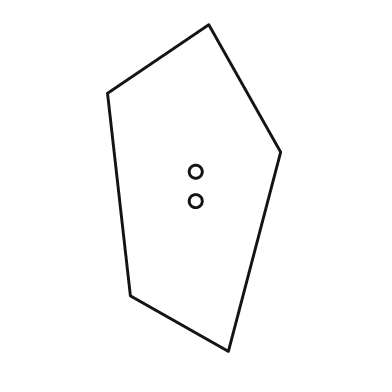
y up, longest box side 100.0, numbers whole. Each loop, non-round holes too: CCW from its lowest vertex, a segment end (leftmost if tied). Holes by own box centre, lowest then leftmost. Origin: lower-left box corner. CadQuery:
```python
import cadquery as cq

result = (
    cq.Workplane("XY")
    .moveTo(37.0, 0.0)
    .lineTo(53.0, 61.0)
    .lineTo(31.0, 100.0)
    .lineTo(0.0, 79.0)
    .lineTo(7.0, 17.0)
    .close()
    .moveTo(27.0, 46.0)
    .circle(2.0)
    .moveTo(27.0, 55.0)
    .circle(2.0)
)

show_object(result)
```